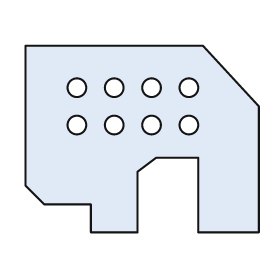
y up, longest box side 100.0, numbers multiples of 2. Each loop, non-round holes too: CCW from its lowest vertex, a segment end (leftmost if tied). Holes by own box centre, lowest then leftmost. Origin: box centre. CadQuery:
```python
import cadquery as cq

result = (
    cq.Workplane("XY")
    .moveTo(-22.0, -40.0)
    .lineTo(-2.0, -40.0)
    .lineTo(-2.0, -14.0)
    .lineTo(6.0, -8.0)
    .lineTo(24.0, -8.0)
    .lineTo(24.0, -40.0)
    .lineTo(50.0, -40.0)
    .lineTo(50.0, 14.0)
    .lineTo(26.0, 40.0)
    .lineTo(-50.0, 40.0)
    .lineTo(-50.0, -20.0)
    .lineTo(-42.0, -28.0)
    .lineTo(-22.0, -28.0)
    .close()
    .moveTo(-28.0, 6.0)
    .circle(4.0)
    .moveTo(-12.0, 6.0)
    .circle(4.0)
    .moveTo(4.0, 6.0)
    .circle(4.0)
    .moveTo(20.0, 6.0)
    .circle(4.0)
    .moveTo(-28.0, 22.0)
    .circle(4.0)
    .moveTo(-12.0, 22.0)
    .circle(4.0)
    .moveTo(4.0, 22.0)
    .circle(4.0)
    .moveTo(20.0, 22.0)
    .circle(4.0)
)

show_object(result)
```